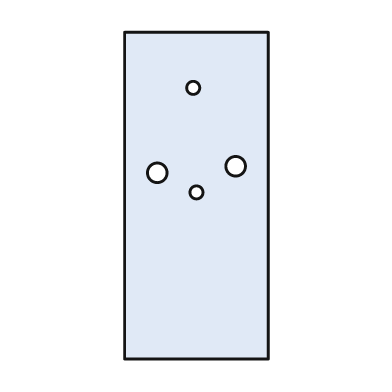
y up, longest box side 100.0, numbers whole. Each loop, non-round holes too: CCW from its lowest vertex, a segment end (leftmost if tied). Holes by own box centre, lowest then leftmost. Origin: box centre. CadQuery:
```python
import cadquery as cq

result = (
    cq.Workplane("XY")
    .moveTo(-22.0, -50.0)
    .lineTo(22.0, -50.0)
    .lineTo(22.0, 50.0)
    .lineTo(-22.0, 50.0)
    .close()
    .moveTo(0.0, 1.0)
    .circle(2.0)
    .moveTo(-12.0, 7.0)
    .circle(3.0)
    .moveTo(12.0, 9.0)
    .circle(3.0)
    .moveTo(-1.0, 33.0)
    .circle(2.0)
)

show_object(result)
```